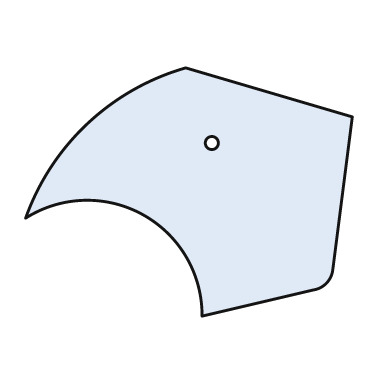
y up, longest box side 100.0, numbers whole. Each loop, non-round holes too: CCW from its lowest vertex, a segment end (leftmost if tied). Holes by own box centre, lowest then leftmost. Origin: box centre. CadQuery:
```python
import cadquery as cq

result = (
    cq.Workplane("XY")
    .moveTo(4.0, -38.0)
    .lineTo(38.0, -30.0)
    .threePointArc((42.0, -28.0), (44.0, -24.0))
    .lineTo(50.0, 23.0)
    .lineTo(-1.0, 38.0)
    .threePointArc((-31.0, 21.0), (-50.0, -8.0))
    .threePointArc((-14.0, -7.0), (4.0, -38.0))
    .close()
    .moveTo(7.0, 15.0)
    .circle(2.0)
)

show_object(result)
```